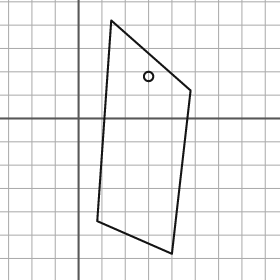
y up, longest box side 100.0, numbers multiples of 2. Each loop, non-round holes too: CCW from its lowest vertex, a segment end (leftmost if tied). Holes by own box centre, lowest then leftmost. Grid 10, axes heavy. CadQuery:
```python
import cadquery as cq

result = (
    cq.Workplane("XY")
    .moveTo(40.0, -58.0)
    .lineTo(48.0, 12.0)
    .lineTo(14.0, 42.0)
    .lineTo(8.0, -44.0)
    .close()
    .moveTo(30.0, 18.0)
    .circle(2.0)
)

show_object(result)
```